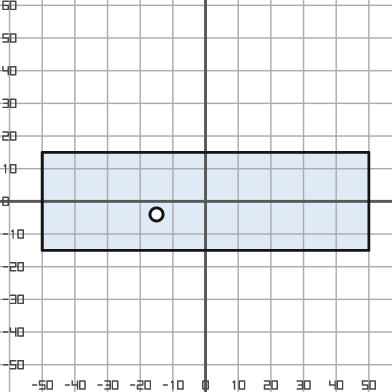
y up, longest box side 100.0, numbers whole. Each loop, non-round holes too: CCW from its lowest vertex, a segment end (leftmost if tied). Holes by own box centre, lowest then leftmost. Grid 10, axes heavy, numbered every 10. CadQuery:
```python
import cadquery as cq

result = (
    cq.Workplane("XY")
    .moveTo(-50.0, -15.0)
    .lineTo(50.0, -15.0)
    .lineTo(50.0, 15.0)
    .lineTo(-50.0, 15.0)
    .close()
    .moveTo(-15.0, -4.0)
    .circle(2.0)
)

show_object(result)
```